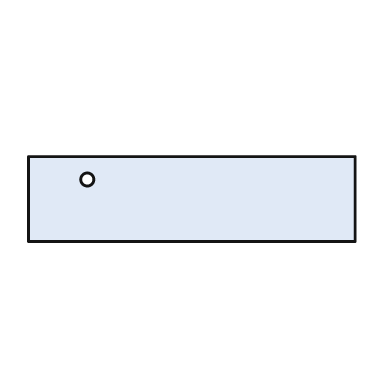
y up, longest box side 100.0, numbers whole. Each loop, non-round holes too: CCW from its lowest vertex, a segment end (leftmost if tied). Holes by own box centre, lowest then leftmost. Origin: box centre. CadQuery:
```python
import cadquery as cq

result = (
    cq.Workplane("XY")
    .moveTo(-50.0, -13.0)
    .lineTo(50.0, -13.0)
    .lineTo(50.0, 13.0)
    .lineTo(-50.0, 13.0)
    .close()
    .moveTo(-32.0, 6.0)
    .circle(2.0)
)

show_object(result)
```